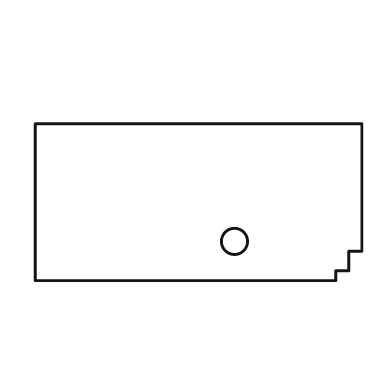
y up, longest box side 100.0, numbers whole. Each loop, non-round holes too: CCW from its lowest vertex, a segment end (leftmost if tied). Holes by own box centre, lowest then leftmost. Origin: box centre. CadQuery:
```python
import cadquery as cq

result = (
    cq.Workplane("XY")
    .moveTo(-50.0, -24.0)
    .lineTo(42.0, -24.0)
    .lineTo(42.0, -21.0)
    .lineTo(46.0, -21.0)
    .lineTo(46.0, -15.0)
    .lineTo(50.0, -15.0)
    .lineTo(50.0, 24.0)
    .lineTo(-50.0, 24.0)
    .close()
    .moveTo(11.0, -12.0)
    .circle(4.0)
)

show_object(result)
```